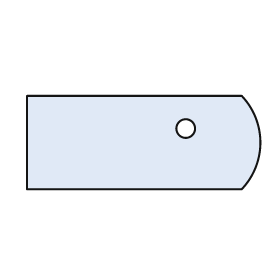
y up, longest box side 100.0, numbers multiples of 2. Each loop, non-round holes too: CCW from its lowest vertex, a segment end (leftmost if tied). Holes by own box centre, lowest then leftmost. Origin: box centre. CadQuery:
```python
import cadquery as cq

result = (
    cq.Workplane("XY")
    .moveTo(-50.0, -20.0)
    .lineTo(42.0, -20.0)
    .threePointArc((50.0, 0.0), (42.0, 20.0))
    .lineTo(-50.0, 20.0)
    .close()
    .moveTo(18.0, 6.0)
    .circle(4.0)
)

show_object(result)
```